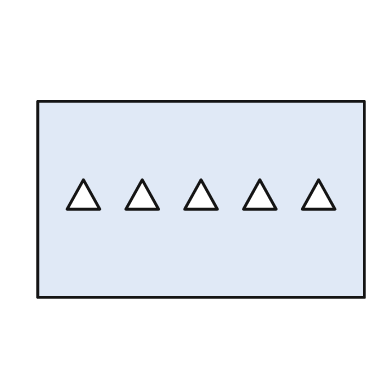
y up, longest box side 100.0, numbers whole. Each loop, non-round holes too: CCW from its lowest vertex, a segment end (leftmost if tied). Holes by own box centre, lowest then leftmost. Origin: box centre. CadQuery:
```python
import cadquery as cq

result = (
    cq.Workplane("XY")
    .moveTo(-50.0, -30.0)
    .lineTo(50.0, -30.0)
    .lineTo(50.0, 30.0)
    .lineTo(-50.0, 30.0)
    .close()
    .moveTo(-41.0, -3.0)
    .lineTo(-31.0, -3.0)
    .lineTo(-36.0, 6.0)
    .close()
    .moveTo(-23.0, -3.0)
    .lineTo(-13.0, -3.0)
    .lineTo(-18.0, 6.0)
    .close()
    .moveTo(-5.0, -3.0)
    .lineTo(5.0, -3.0)
    .lineTo(0.0, 6.0)
    .close()
    .moveTo(13.0, -3.0)
    .lineTo(23.0, -3.0)
    .lineTo(18.0, 6.0)
    .close()
    .moveTo(31.0, -3.0)
    .lineTo(41.0, -3.0)
    .lineTo(36.0, 6.0)
    .close()
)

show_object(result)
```